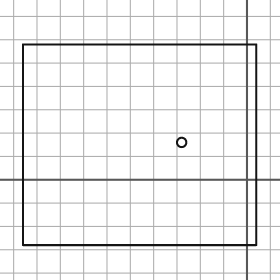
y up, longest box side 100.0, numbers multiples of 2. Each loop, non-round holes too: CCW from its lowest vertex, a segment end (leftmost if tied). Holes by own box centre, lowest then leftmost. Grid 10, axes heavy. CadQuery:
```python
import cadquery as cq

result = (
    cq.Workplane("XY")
    .moveTo(-96.0, -28.0)
    .lineTo(4.0, -28.0)
    .lineTo(4.0, 58.0)
    .lineTo(-96.0, 58.0)
    .close()
    .moveTo(-28.0, 16.0)
    .circle(2.0)
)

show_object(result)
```